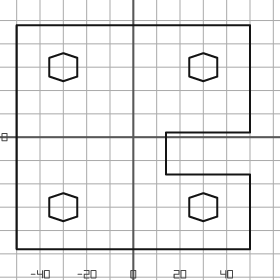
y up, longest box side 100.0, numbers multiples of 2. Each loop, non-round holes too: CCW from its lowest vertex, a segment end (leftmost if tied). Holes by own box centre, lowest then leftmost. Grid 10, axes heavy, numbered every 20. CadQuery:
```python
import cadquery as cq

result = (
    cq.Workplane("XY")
    .moveTo(-50.0, -48.0)
    .lineTo(50.0, -48.0)
    .lineTo(50.0, -16.0)
    .lineTo(14.0, -16.0)
    .lineTo(14.0, 2.0)
    .lineTo(50.0, 2.0)
    .lineTo(50.0, 48.0)
    .lineTo(-50.0, 48.0)
    .close()
    .moveTo(-30.0, -36.0)
    .lineTo(-24.0, -34.0)
    .lineTo(-24.0, -26.0)
    .lineTo(-30.0, -24.0)
    .lineTo(-36.0, -26.0)
    .lineTo(-36.0, -34.0)
    .close()
    .moveTo(30.0, -36.0)
    .lineTo(36.0, -34.0)
    .lineTo(36.0, -26.0)
    .lineTo(30.0, -24.0)
    .lineTo(24.0, -26.0)
    .lineTo(24.0, -34.0)
    .close()
    .moveTo(-30.0, 24.0)
    .lineTo(-24.0, 26.0)
    .lineTo(-24.0, 34.0)
    .lineTo(-30.0, 36.0)
    .lineTo(-36.0, 34.0)
    .lineTo(-36.0, 26.0)
    .close()
    .moveTo(30.0, 24.0)
    .lineTo(36.0, 26.0)
    .lineTo(36.0, 34.0)
    .lineTo(30.0, 36.0)
    .lineTo(24.0, 34.0)
    .lineTo(24.0, 26.0)
    .close()
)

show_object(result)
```